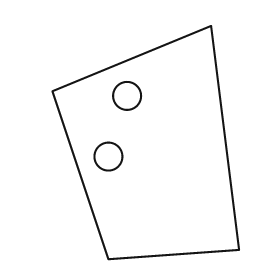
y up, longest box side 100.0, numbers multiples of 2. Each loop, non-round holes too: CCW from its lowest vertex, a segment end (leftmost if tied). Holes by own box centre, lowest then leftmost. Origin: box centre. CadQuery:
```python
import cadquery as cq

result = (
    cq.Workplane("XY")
    .moveTo(-16.0, -50.0)
    .lineTo(40.0, -46.0)
    .lineTo(28.0, 50.0)
    .lineTo(-40.0, 22.0)
    .close()
    .moveTo(-16.0, -6.0)
    .circle(6.0)
    .moveTo(-8.0, 20.0)
    .circle(6.0)
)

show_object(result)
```